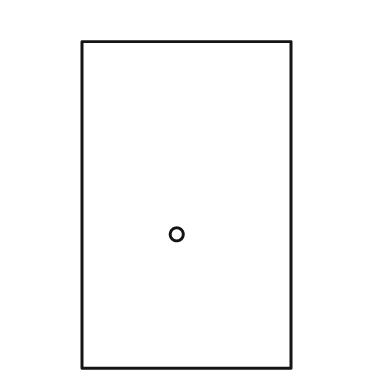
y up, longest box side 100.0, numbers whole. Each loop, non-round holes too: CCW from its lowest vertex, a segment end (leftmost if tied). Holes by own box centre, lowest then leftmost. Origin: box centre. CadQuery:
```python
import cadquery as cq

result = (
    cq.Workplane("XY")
    .moveTo(-32.0, -50.0)
    .lineTo(32.0, -50.0)
    .lineTo(32.0, 50.0)
    .lineTo(-32.0, 50.0)
    .close()
    .moveTo(-3.0, -9.0)
    .circle(2.0)
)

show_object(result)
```